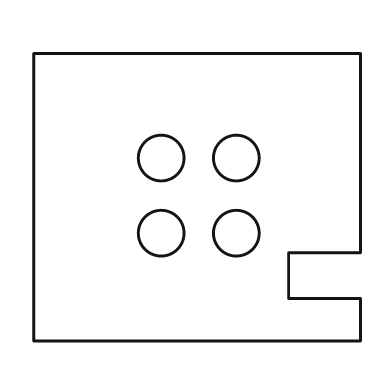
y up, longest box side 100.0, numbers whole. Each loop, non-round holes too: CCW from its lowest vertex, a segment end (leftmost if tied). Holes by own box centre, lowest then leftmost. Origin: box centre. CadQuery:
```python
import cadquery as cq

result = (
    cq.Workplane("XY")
    .moveTo(-50.0, -44.0)
    .lineTo(50.0, -44.0)
    .lineTo(50.0, -31.0)
    .lineTo(28.0, -31.0)
    .lineTo(28.0, -17.0)
    .lineTo(50.0, -17.0)
    .lineTo(50.0, 44.0)
    .lineTo(-50.0, 44.0)
    .close()
    .moveTo(-11.0, -11.0)
    .circle(7.0)
    .moveTo(12.0, -11.0)
    .circle(7.0)
    .moveTo(-11.0, 12.0)
    .circle(7.0)
    .moveTo(12.0, 12.0)
    .circle(7.0)
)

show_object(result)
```